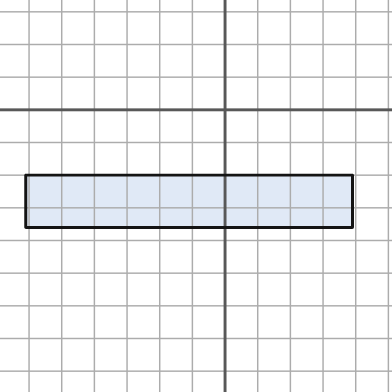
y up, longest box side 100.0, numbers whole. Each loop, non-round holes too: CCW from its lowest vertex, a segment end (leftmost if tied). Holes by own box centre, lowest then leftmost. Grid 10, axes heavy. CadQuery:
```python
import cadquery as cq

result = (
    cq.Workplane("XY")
    .moveTo(-61.0, -36.0)
    .lineTo(39.0, -36.0)
    .lineTo(39.0, -20.0)
    .lineTo(-61.0, -20.0)
    .close()
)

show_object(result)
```